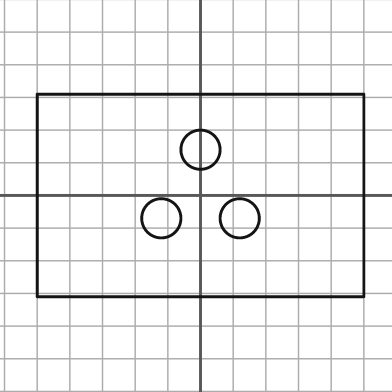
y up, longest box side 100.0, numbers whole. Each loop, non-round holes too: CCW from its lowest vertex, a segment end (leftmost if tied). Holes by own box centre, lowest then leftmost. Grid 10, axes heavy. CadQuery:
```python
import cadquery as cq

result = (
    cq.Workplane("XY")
    .moveTo(-50.0, -31.0)
    .lineTo(50.0, -31.0)
    .lineTo(50.0, 31.0)
    .lineTo(-50.0, 31.0)
    .close()
    .moveTo(-12.0, -7.0)
    .circle(6.0)
    .moveTo(12.0, -7.0)
    .circle(6.0)
    .moveTo(0.0, 14.0)
    .circle(6.0)
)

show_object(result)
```